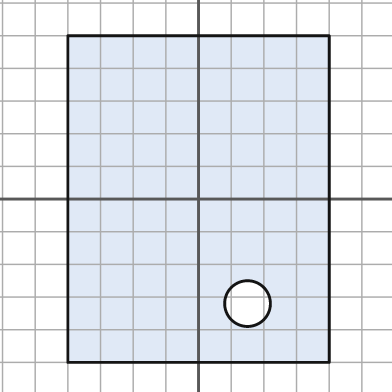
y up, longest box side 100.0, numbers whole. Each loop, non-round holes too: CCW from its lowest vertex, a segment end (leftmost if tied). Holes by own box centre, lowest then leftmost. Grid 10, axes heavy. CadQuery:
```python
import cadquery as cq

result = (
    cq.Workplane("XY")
    .moveTo(-40.0, -50.0)
    .lineTo(40.0, -50.0)
    .lineTo(40.0, 50.0)
    .lineTo(-40.0, 50.0)
    .close()
    .moveTo(15.0, -32.0)
    .circle(7.0)
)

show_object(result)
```